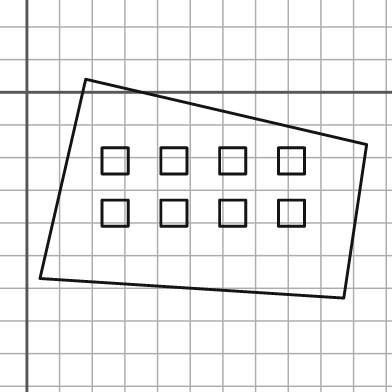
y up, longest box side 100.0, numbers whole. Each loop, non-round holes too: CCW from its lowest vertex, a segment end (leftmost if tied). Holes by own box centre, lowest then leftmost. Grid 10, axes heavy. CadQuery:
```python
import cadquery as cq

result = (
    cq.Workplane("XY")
    .moveTo(97.0, -63.0)
    .lineTo(104.0, -16.0)
    .lineTo(18.0, 4.0)
    .lineTo(4.0, -57.0)
    .close()
    .moveTo(23.0, -41.0)
    .lineTo(31.0, -41.0)
    .lineTo(31.0, -33.0)
    .lineTo(23.0, -33.0)
    .close()
    .moveTo(41.0, -41.0)
    .lineTo(49.0, -41.0)
    .lineTo(49.0, -33.0)
    .lineTo(41.0, -33.0)
    .close()
    .moveTo(59.0, -41.0)
    .lineTo(67.0, -41.0)
    .lineTo(67.0, -33.0)
    .lineTo(59.0, -33.0)
    .close()
    .moveTo(77.0, -41.0)
    .lineTo(85.0, -41.0)
    .lineTo(85.0, -33.0)
    .lineTo(77.0, -33.0)
    .close()
    .moveTo(23.0, -25.0)
    .lineTo(31.0, -25.0)
    .lineTo(31.0, -17.0)
    .lineTo(23.0, -17.0)
    .close()
    .moveTo(41.0, -25.0)
    .lineTo(49.0, -25.0)
    .lineTo(49.0, -17.0)
    .lineTo(41.0, -17.0)
    .close()
    .moveTo(59.0, -25.0)
    .lineTo(67.0, -25.0)
    .lineTo(67.0, -17.0)
    .lineTo(59.0, -17.0)
    .close()
    .moveTo(77.0, -25.0)
    .lineTo(85.0, -25.0)
    .lineTo(85.0, -17.0)
    .lineTo(77.0, -17.0)
    .close()
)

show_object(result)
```